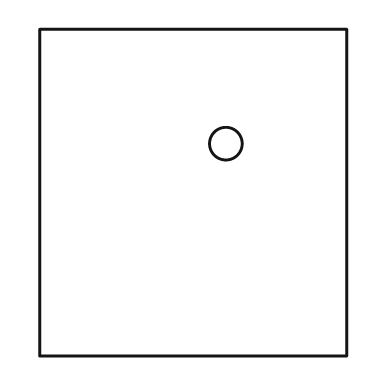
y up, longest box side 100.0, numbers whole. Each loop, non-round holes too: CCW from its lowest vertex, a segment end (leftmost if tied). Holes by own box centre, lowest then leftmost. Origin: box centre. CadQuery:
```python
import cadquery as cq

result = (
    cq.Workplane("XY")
    .moveTo(-47.0, -50.0)
    .lineTo(47.0, -50.0)
    .lineTo(47.0, 50.0)
    .lineTo(-47.0, 50.0)
    .close()
    .moveTo(10.0, 15.0)
    .circle(5.0)
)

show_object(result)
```